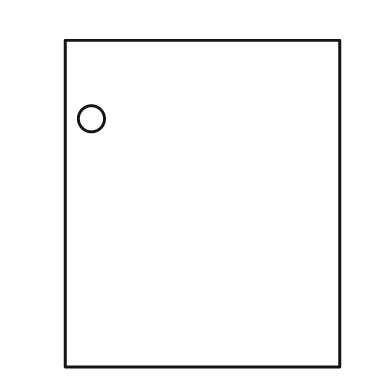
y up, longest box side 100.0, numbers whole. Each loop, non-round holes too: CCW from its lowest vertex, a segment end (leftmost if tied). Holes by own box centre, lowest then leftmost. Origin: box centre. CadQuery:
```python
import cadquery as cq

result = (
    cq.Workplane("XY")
    .moveTo(-42.0, -50.0)
    .lineTo(42.0, -50.0)
    .lineTo(42.0, 50.0)
    .lineTo(-42.0, 50.0)
    .close()
    .moveTo(-34.0, 26.0)
    .circle(4.0)
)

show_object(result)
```